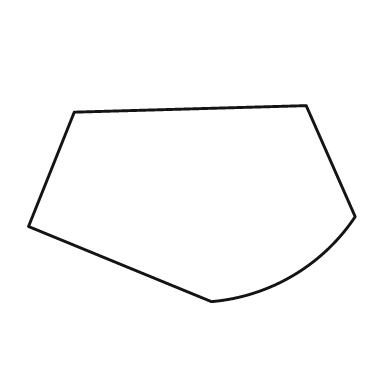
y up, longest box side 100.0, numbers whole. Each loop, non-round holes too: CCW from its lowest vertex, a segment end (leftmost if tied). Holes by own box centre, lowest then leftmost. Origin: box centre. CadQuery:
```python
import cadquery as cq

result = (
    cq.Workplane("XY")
    .moveTo(6.0, -30.0)
    .threePointArc((31.0, -22.0), (50.0, -4.0))
    .lineTo(35.0, 30.0)
    .lineTo(-36.0, 28.0)
    .lineTo(-50.0, -7.0)
    .close()
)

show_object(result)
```